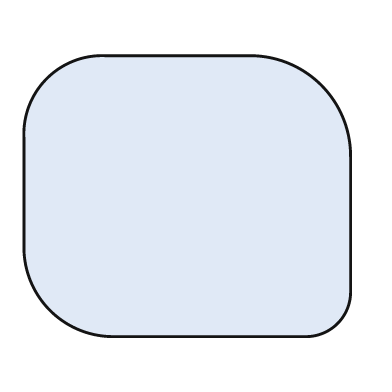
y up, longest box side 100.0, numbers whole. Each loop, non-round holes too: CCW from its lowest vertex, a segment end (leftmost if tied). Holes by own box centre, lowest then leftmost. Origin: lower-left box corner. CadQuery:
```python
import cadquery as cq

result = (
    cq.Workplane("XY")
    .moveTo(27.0, 0.0)
    .lineTo(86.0, 0.0)
    .threePointArc((96.0, 4.0), (100.0, 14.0))
    .lineTo(100.0, 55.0)
    .threePointArc((91.0, 77.0), (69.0, 86.0))
    .lineTo(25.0, 86.0)
    .threePointArc((7.0, 79.0), (0.0, 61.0))
    .lineTo(0.0, 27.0)
    .threePointArc((8.0, 8.0), (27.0, 0.0))
    .close()
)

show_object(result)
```